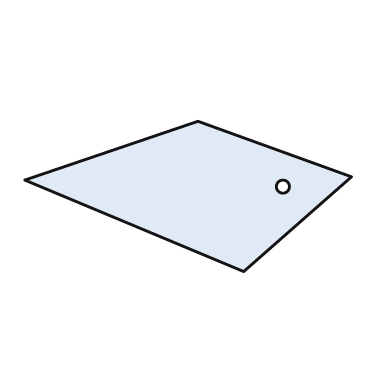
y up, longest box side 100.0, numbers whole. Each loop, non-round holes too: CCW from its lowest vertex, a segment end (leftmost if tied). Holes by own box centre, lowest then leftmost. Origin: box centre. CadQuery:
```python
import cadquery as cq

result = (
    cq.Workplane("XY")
    .moveTo(17.0, -23.0)
    .lineTo(50.0, 6.0)
    .lineTo(3.0, 23.0)
    .lineTo(-50.0, 5.0)
    .close()
    .moveTo(29.0, 3.0)
    .circle(2.0)
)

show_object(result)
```